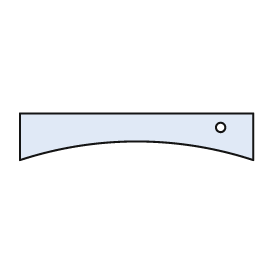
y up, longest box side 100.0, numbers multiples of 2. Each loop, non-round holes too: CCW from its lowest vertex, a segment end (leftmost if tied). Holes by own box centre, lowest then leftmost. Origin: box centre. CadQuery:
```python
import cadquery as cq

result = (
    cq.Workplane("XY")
    .moveTo(-50.0, -10.0)
    .threePointArc((0.0, -2.0), (50.0, -10.0))
    .lineTo(50.0, 10.0)
    .lineTo(-50.0, 10.0)
    .close()
    .moveTo(36.0, 4.0)
    .circle(2.0)
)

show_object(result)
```